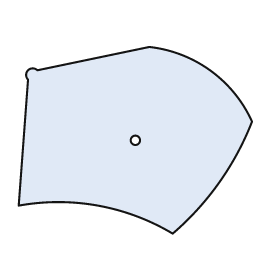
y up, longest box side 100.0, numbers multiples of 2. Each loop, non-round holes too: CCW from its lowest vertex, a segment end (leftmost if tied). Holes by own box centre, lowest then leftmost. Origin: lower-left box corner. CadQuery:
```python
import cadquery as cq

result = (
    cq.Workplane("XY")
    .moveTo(66.0, 0.0)
    .threePointArc((86.0, 22.0), (100.0, 48.0))
    .threePointArc((82.0, 70.0), (56.0, 80.0))
    .lineTo(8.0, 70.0)
    .threePointArc((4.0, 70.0), (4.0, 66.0))
    .lineTo(0.0, 12.0)
    .threePointArc((34.0, 12.0), (66.0, 0.0))
    .close()
    .moveTo(50.0, 40.0)
    .circle(2.0)
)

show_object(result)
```